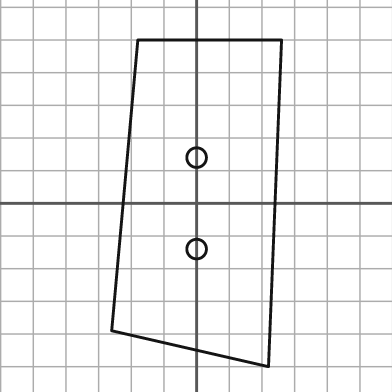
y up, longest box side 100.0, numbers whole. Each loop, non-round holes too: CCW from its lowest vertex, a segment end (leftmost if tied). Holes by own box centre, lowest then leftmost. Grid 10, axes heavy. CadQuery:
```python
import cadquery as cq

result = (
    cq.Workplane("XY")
    .moveTo(22.0, -50.0)
    .lineTo(26.0, 50.0)
    .lineTo(-18.0, 50.0)
    .lineTo(-26.0, -39.0)
    .close()
    .moveTo(0.0, -14.0)
    .circle(3.0)
    .moveTo(0.0, 14.0)
    .circle(3.0)
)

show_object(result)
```